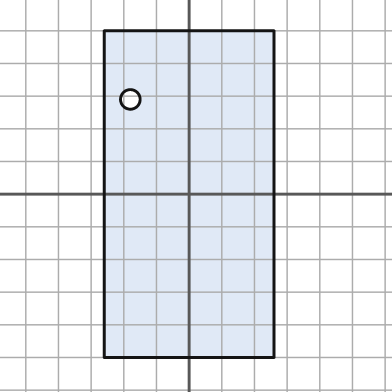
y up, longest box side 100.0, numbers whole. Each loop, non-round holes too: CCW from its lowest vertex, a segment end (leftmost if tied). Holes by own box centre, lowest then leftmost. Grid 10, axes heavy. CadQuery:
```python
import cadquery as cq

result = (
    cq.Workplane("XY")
    .moveTo(-26.0, -50.0)
    .lineTo(26.0, -50.0)
    .lineTo(26.0, 50.0)
    .lineTo(-26.0, 50.0)
    .close()
    .moveTo(-18.0, 29.0)
    .circle(3.0)
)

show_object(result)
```